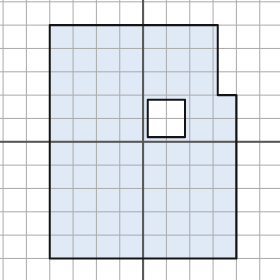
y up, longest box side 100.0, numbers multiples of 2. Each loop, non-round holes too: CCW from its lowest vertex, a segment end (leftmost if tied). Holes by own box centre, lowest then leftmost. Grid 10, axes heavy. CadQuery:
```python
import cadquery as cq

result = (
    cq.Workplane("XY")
    .moveTo(-40.0, -50.0)
    .lineTo(40.0, -50.0)
    .lineTo(40.0, 20.0)
    .lineTo(32.0, 20.0)
    .lineTo(32.0, 50.0)
    .lineTo(-40.0, 50.0)
    .close()
    .moveTo(2.0, 2.0)
    .lineTo(18.0, 2.0)
    .lineTo(18.0, 18.0)
    .lineTo(2.0, 18.0)
    .close()
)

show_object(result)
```